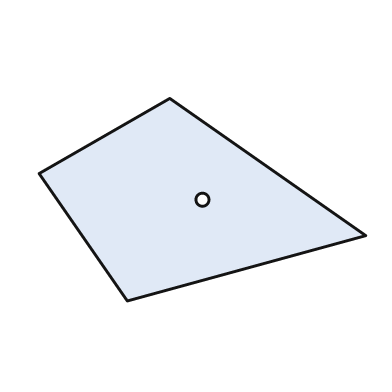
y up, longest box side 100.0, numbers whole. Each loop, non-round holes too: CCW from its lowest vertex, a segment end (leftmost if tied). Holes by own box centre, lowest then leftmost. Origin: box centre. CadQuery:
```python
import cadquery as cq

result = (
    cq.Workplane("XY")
    .moveTo(-23.0, -31.0)
    .lineTo(50.0, -11.0)
    .lineTo(-10.0, 31.0)
    .lineTo(-50.0, 8.0)
    .close()
    .moveTo(0.0, 0.0)
    .circle(2.0)
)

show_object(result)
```